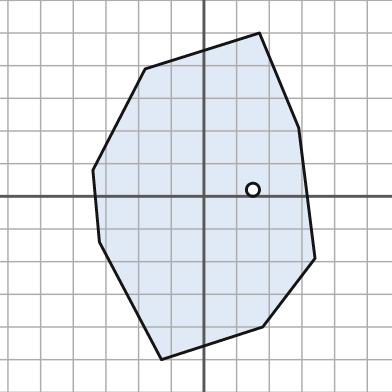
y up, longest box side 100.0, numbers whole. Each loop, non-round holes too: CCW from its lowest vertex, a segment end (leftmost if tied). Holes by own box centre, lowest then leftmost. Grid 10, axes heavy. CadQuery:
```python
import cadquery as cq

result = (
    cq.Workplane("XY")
    .moveTo(-13.0, -50.0)
    .lineTo(18.0, -40.0)
    .lineTo(34.0, -19.0)
    .lineTo(29.0, 21.0)
    .lineTo(17.0, 50.0)
    .lineTo(-18.0, 39.0)
    .lineTo(-34.0, 8.0)
    .lineTo(-32.0, -14.0)
    .close()
    .moveTo(15.0, 2.0)
    .circle(2.0)
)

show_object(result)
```